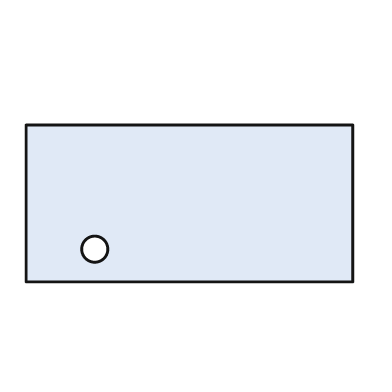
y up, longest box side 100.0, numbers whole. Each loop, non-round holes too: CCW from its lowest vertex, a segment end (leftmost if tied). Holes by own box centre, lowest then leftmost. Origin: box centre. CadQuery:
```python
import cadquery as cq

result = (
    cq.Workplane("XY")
    .moveTo(-50.0, -24.0)
    .lineTo(50.0, -24.0)
    .lineTo(50.0, 24.0)
    .lineTo(-50.0, 24.0)
    .close()
    .moveTo(-29.0, -14.0)
    .circle(4.0)
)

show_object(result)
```